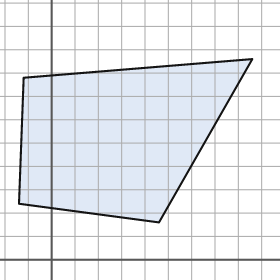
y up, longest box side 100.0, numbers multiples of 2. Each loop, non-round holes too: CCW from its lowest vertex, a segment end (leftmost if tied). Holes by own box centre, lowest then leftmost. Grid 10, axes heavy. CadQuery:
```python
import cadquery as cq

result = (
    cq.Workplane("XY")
    .moveTo(46.0, 16.0)
    .lineTo(86.0, 86.0)
    .lineTo(-12.0, 78.0)
    .lineTo(-14.0, 24.0)
    .close()
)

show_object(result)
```